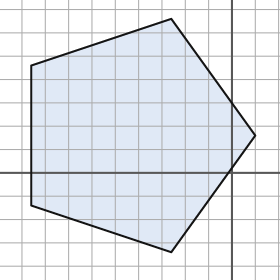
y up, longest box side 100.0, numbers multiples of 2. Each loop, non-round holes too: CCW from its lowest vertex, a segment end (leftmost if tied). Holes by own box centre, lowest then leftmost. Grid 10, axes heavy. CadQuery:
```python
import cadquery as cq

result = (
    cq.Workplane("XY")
    .moveTo(-26.0, -34.0)
    .lineTo(10.0, 16.0)
    .lineTo(-26.0, 66.0)
    .lineTo(-86.0, 46.0)
    .lineTo(-86.0, -14.0)
    .close()
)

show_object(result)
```